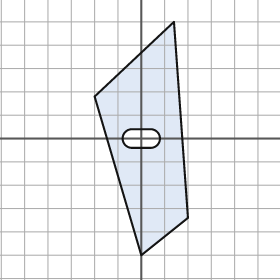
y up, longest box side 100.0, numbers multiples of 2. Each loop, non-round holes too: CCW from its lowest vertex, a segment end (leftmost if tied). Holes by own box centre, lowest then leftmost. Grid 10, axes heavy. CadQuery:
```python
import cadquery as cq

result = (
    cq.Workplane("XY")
    .moveTo(0.0, -50.0)
    .lineTo(20.0, -34.0)
    .lineTo(14.0, 50.0)
    .lineTo(-20.0, 18.0)
    .close()
    .moveTo(-4.0, -4.0)
    .lineTo(4.0, -4.0)
    .threePointArc((8.0, 0.0), (4.0, 4.0))
    .lineTo(-4.0, 4.0)
    .threePointArc((-8.0, 0.0), (-4.0, -4.0))
    .close()
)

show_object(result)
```